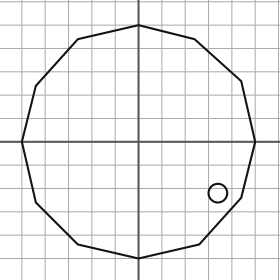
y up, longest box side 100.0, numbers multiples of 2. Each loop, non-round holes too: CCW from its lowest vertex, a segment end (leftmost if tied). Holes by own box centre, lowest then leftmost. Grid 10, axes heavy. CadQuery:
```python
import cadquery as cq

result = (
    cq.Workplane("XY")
    .moveTo(0.0, -50.0)
    .lineTo(26.0, -44.0)
    .lineTo(44.0, -24.0)
    .lineTo(50.0, 0.0)
    .lineTo(44.0, 26.0)
    .lineTo(24.0, 44.0)
    .lineTo(0.0, 50.0)
    .lineTo(-26.0, 44.0)
    .lineTo(-44.0, 24.0)
    .lineTo(-50.0, 0.0)
    .lineTo(-44.0, -26.0)
    .lineTo(-26.0, -44.0)
    .close()
    .moveTo(34.0, -22.0)
    .circle(4.0)
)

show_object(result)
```